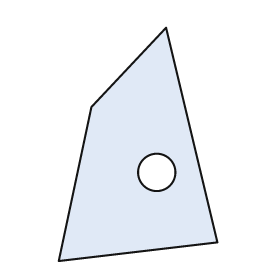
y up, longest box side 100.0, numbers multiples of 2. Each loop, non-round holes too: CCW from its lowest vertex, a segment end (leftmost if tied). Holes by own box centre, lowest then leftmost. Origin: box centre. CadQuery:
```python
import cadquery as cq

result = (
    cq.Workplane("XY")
    .moveTo(-34.0, -50.0)
    .lineTo(34.0, -42.0)
    .lineTo(12.0, 50.0)
    .lineTo(-20.0, 16.0)
    .close()
    .moveTo(8.0, -12.0)
    .circle(8.0)
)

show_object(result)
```